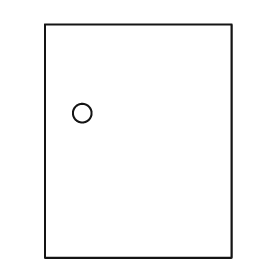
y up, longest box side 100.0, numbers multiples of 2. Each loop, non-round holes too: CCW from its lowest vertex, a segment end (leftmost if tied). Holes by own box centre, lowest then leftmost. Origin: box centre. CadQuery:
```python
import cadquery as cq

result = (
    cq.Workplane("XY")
    .moveTo(-40.0, -50.0)
    .lineTo(40.0, -50.0)
    .lineTo(40.0, 50.0)
    .lineTo(-40.0, 50.0)
    .close()
    .moveTo(-24.0, 12.0)
    .circle(4.0)
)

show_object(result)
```